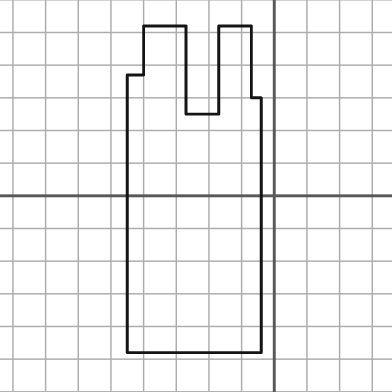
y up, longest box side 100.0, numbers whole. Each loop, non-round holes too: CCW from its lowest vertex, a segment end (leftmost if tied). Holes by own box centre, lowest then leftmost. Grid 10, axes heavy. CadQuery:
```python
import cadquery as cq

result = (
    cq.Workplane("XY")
    .moveTo(-45.0, -48.0)
    .lineTo(-4.0, -48.0)
    .lineTo(-4.0, 30.0)
    .lineTo(-7.0, 30.0)
    .lineTo(-7.0, 52.0)
    .lineTo(-17.0, 52.0)
    .lineTo(-17.0, 25.0)
    .lineTo(-27.0, 25.0)
    .lineTo(-27.0, 52.0)
    .lineTo(-40.0, 52.0)
    .lineTo(-40.0, 37.0)
    .lineTo(-45.0, 37.0)
    .close()
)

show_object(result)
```